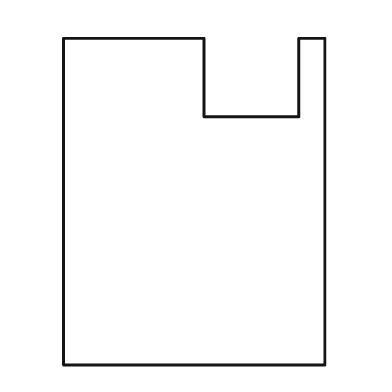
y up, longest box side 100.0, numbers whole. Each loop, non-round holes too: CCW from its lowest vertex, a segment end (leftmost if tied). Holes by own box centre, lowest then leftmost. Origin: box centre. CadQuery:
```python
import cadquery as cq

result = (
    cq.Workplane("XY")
    .moveTo(-40.0, -50.0)
    .lineTo(40.0, -50.0)
    .lineTo(40.0, 50.0)
    .lineTo(32.0, 50.0)
    .lineTo(32.0, 26.0)
    .lineTo(3.0, 26.0)
    .lineTo(3.0, 50.0)
    .lineTo(-40.0, 50.0)
    .close()
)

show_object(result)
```